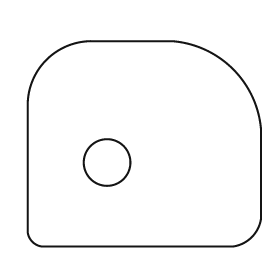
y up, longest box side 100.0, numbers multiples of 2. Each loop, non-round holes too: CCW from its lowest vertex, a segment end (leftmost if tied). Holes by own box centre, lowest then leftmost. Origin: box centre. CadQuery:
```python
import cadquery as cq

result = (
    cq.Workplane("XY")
    .moveTo(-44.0, -44.0)
    .lineTo(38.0, -44.0)
    .threePointArc((46.0, -40.0), (50.0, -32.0))
    .lineTo(50.0, 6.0)
    .threePointArc((38.0, 32.0), (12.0, 44.0))
    .lineTo(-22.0, 44.0)
    .threePointArc((-42.0, 36.0), (-50.0, 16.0))
    .lineTo(-50.0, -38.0)
    .threePointArc((-48.0, -42.0), (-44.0, -44.0))
    .close()
    .moveTo(-16.0, -8.0)
    .circle(10.0)
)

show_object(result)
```